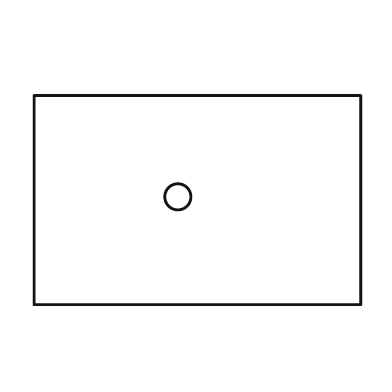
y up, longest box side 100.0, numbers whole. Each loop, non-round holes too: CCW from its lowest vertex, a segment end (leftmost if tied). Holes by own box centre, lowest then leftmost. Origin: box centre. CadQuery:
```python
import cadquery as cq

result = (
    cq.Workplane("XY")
    .moveTo(-50.0, -32.0)
    .lineTo(50.0, -32.0)
    .lineTo(50.0, 32.0)
    .lineTo(-50.0, 32.0)
    .close()
    .moveTo(-6.0, 1.0)
    .circle(4.0)
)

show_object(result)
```